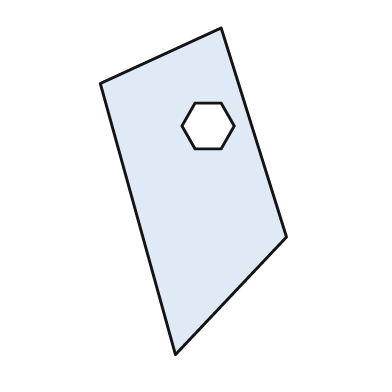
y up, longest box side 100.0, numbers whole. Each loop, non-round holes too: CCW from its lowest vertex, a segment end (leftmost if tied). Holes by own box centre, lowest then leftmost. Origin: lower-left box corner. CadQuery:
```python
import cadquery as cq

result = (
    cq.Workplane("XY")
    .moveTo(23.0, 0.0)
    .lineTo(57.0, 36.0)
    .lineTo(37.0, 100.0)
    .lineTo(0.0, 83.0)
    .close()
    .moveTo(29.0, 63.0)
    .lineTo(37.0, 63.0)
    .lineTo(41.0, 70.0)
    .lineTo(37.0, 77.0)
    .lineTo(29.0, 77.0)
    .lineTo(25.0, 70.0)
    .close()
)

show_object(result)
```